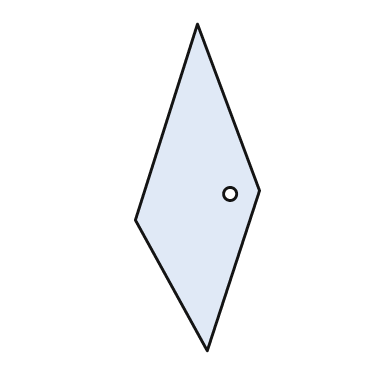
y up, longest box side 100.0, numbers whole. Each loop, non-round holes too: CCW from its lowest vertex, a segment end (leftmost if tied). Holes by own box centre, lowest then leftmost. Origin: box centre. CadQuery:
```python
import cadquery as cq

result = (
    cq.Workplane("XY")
    .moveTo(3.0, -50.0)
    .lineTo(19.0, -1.0)
    .lineTo(0.0, 50.0)
    .lineTo(-19.0, -10.0)
    .close()
    .moveTo(10.0, -2.0)
    .circle(2.0)
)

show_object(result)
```